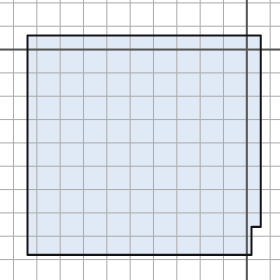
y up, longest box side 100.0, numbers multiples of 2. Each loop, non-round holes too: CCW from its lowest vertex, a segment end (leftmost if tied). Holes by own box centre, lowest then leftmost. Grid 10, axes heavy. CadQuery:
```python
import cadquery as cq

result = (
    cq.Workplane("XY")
    .moveTo(-94.0, -88.0)
    .lineTo(2.0, -88.0)
    .lineTo(2.0, -76.0)
    .lineTo(6.0, -76.0)
    .lineTo(6.0, 6.0)
    .lineTo(-94.0, 6.0)
    .close()
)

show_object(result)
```